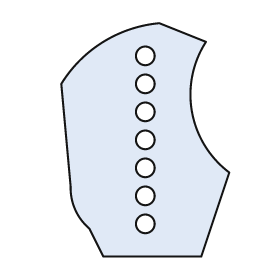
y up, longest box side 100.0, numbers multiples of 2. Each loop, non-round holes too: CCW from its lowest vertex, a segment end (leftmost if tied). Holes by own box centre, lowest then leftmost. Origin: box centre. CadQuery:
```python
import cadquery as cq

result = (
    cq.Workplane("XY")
    .moveTo(-18.0, -50.0)
    .lineTo(24.0, -50.0)
    .lineTo(36.0, -14.0)
    .threePointArc((20.0, 12.0), (26.0, 42.0))
    .lineTo(6.0, 50.0)
    .threePointArc((-18.0, 42.0), (-36.0, 24.0))
    .lineTo(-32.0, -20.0)
    .threePointArc((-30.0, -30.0), (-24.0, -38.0))
    .close()
    .moveTo(0.0, -36.0)
    .circle(4.0)
    .moveTo(0.0, -24.0)
    .circle(4.0)
    .moveTo(0.0, -12.0)
    .circle(4.0)
    .moveTo(0.0, 0.0)
    .circle(4.0)
    .moveTo(0.0, 12.0)
    .circle(4.0)
    .moveTo(0.0, 24.0)
    .circle(4.0)
    .moveTo(0.0, 36.0)
    .circle(4.0)
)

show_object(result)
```